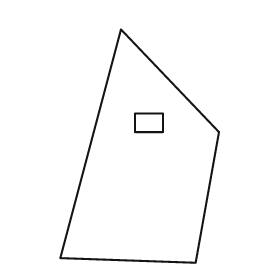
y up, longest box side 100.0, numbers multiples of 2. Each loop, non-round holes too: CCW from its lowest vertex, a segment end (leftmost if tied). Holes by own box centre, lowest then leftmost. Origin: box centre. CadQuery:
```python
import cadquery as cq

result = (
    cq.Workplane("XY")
    .moveTo(24.0, -50.0)
    .lineTo(34.0, 6.0)
    .lineTo(-8.0, 50.0)
    .lineTo(-34.0, -48.0)
    .close()
    .moveTo(-2.0, 6.0)
    .lineTo(10.0, 6.0)
    .lineTo(10.0, 14.0)
    .lineTo(-2.0, 14.0)
    .close()
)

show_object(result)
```